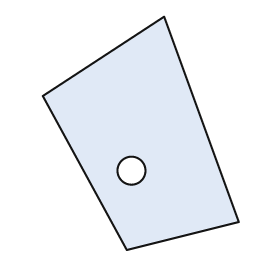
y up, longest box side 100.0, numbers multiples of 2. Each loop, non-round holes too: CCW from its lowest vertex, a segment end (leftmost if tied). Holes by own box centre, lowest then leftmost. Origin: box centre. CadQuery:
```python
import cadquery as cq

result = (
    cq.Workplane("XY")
    .moveTo(-6.0, -50.0)
    .lineTo(42.0, -38.0)
    .lineTo(10.0, 50.0)
    .lineTo(-42.0, 16.0)
    .close()
    .moveTo(-4.0, -16.0)
    .circle(6.0)
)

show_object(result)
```